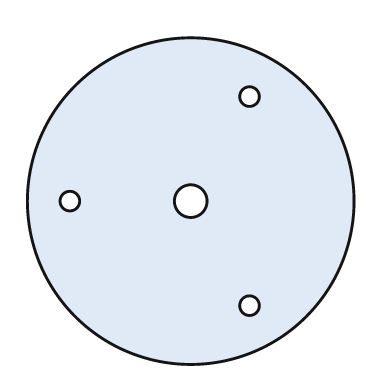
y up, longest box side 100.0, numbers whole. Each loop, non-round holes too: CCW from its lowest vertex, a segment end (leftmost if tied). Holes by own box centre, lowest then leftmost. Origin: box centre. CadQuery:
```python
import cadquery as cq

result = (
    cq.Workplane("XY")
    .moveTo(0.0, 0.0)
    .circle(50.0)
    .moveTo(18.0, -32.0)
    .circle(3.0)
    .moveTo(-37.0, 0.0)
    .circle(3.0)
    .moveTo(0.0, 0.0)
    .circle(5.0)
    .moveTo(18.0, 32.0)
    .circle(3.0)
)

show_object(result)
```